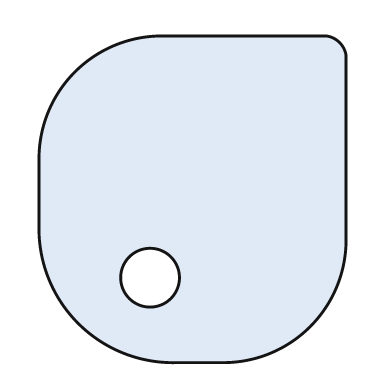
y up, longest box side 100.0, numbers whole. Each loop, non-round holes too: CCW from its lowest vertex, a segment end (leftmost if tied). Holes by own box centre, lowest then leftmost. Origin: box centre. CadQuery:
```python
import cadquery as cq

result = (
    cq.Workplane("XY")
    .moveTo(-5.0, -50.0)
    .lineTo(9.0, -50.0)
    .threePointArc((36.0, -39.0), (47.0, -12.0))
    .lineTo(47.0, 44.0)
    .threePointArc((45.0, 48.0), (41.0, 50.0))
    .lineTo(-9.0, 50.0)
    .threePointArc((-36.0, 39.0), (-47.0, 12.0))
    .lineTo(-47.0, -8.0)
    .threePointArc((-35.0, -38.0), (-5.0, -50.0))
    .close()
    .moveTo(-13.0, -24.0)
    .circle(9.0)
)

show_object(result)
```